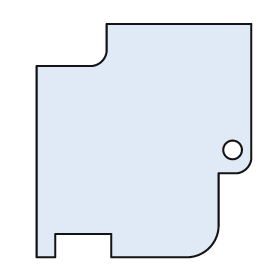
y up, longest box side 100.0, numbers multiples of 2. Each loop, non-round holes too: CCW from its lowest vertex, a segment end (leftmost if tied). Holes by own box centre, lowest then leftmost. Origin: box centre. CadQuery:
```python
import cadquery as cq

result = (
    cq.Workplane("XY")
    .moveTo(-46.0, -50.0)
    .lineTo(-38.0, -50.0)
    .lineTo(-38.0, -40.0)
    .lineTo(-14.0, -40.0)
    .lineTo(-14.0, -50.0)
    .lineTo(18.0, -50.0)
    .threePointArc((28.0, -46.0), (32.0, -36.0))
    .lineTo(32.0, -14.0)
    .lineTo(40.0, -14.0)
    .threePointArc((44.0, -12.0), (46.0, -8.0))
    .lineTo(46.0, 50.0)
    .lineTo(-16.0, 50.0)
    .lineTo(-16.0, 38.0)
    .threePointArc((-18.0, 34.0), (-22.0, 32.0))
    .lineTo(-46.0, 32.0)
    .close()
    .moveTo(38.0, -4.0)
    .circle(4.0)
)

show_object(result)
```